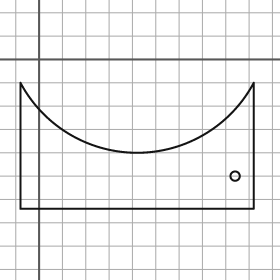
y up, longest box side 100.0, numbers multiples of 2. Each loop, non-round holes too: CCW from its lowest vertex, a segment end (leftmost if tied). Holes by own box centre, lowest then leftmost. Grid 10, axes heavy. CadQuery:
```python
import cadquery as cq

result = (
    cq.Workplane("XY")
    .moveTo(-8.0, -64.0)
    .lineTo(92.0, -64.0)
    .lineTo(92.0, -10.0)
    .threePointArc((42.0, -40.0), (-8.0, -10.0))
    .close()
    .moveTo(84.0, -50.0)
    .circle(2.0)
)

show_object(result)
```